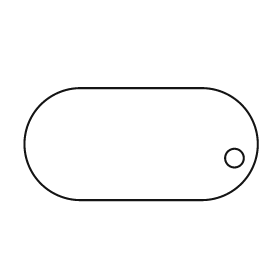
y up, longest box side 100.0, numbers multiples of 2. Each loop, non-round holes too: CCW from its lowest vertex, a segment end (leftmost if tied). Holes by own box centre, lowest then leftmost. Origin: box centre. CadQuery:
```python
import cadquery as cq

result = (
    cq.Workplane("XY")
    .moveTo(-26.0, -24.0)
    .lineTo(26.0, -24.0)
    .threePointArc((50.0, 0.0), (26.0, 24.0))
    .lineTo(-26.0, 24.0)
    .threePointArc((-50.0, 0.0), (-26.0, -24.0))
    .close()
    .moveTo(40.0, -6.0)
    .circle(4.0)
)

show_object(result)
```